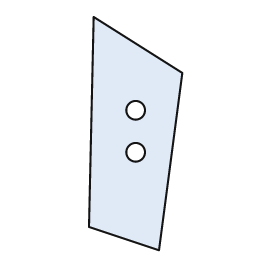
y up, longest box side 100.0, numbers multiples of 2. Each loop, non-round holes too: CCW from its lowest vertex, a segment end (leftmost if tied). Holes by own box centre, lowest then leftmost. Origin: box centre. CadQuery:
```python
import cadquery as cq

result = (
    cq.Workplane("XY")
    .moveTo(10.0, -50.0)
    .lineTo(20.0, 26.0)
    .lineTo(-18.0, 50.0)
    .lineTo(-20.0, -40.0)
    .close()
    .moveTo(0.0, -8.0)
    .circle(4.0)
    .moveTo(0.0, 10.0)
    .circle(4.0)
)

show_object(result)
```